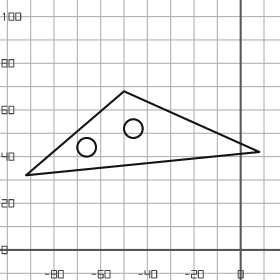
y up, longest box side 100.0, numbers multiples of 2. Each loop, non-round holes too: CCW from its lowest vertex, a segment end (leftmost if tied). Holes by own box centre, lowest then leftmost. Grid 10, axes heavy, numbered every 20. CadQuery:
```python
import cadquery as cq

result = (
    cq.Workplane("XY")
    .moveTo(-92.0, 32.0)
    .lineTo(8.0, 42.0)
    .lineTo(-50.0, 68.0)
    .close()
    .moveTo(-66.0, 44.0)
    .circle(4.0)
    .moveTo(-46.0, 52.0)
    .circle(4.0)
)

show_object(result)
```